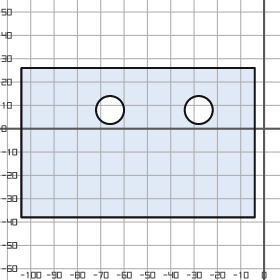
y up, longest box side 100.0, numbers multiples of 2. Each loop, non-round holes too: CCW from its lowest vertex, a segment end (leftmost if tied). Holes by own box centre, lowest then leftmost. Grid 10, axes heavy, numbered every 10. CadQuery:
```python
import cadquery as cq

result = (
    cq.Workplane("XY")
    .moveTo(-104.0, -38.0)
    .lineTo(-4.0, -38.0)
    .lineTo(-4.0, 26.0)
    .lineTo(-104.0, 26.0)
    .close()
    .moveTo(-66.0, 8.0)
    .circle(6.0)
    .moveTo(-28.0, 8.0)
    .circle(6.0)
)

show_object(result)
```